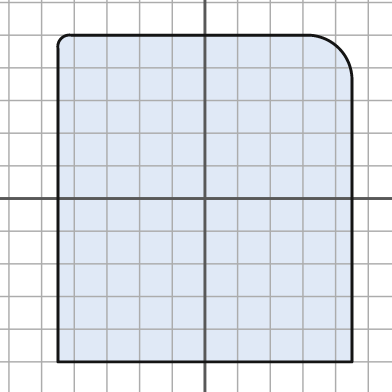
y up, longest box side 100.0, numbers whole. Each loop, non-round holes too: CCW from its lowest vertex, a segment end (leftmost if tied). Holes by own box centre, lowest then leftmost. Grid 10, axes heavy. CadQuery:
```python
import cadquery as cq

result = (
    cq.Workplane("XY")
    .moveTo(-45.0, -50.0)
    .lineTo(45.0, -50.0)
    .lineTo(45.0, 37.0)
    .threePointArc((41.0, 46.0), (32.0, 50.0))
    .lineTo(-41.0, 50.0)
    .threePointArc((-44.0, 49.0), (-45.0, 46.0))
    .close()
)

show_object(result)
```